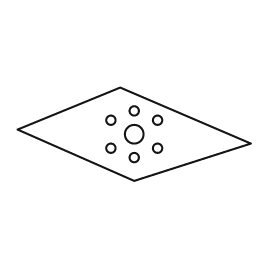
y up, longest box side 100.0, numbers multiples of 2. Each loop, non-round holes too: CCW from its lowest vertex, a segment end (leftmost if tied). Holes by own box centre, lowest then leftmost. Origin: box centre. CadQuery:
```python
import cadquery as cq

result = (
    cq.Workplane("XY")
    .moveTo(0.0, -20.0)
    .lineTo(50.0, -4.0)
    .lineTo(-6.0, 20.0)
    .lineTo(-50.0, 2.0)
    .close()
    .moveTo(0.0, -10.0)
    .circle(2.0)
    .moveTo(-10.0, -6.0)
    .circle(2.0)
    .moveTo(10.0, -6.0)
    .circle(2.0)
    .moveTo(0.0, 0.0)
    .circle(4.0)
    .moveTo(-10.0, 6.0)
    .circle(2.0)
    .moveTo(10.0, 6.0)
    .circle(2.0)
    .moveTo(0.0, 10.0)
    .circle(2.0)
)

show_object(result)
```